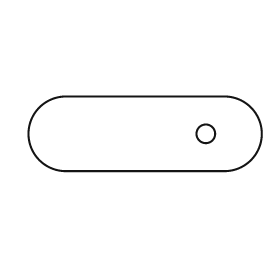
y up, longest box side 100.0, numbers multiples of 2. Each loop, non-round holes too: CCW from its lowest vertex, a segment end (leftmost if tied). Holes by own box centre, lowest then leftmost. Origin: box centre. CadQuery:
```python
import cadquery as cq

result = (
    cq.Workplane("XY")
    .moveTo(-34.0, -16.0)
    .lineTo(34.0, -16.0)
    .threePointArc((50.0, 0.0), (34.0, 16.0))
    .lineTo(-34.0, 16.0)
    .threePointArc((-50.0, 0.0), (-34.0, -16.0))
    .close()
    .moveTo(26.0, 0.0)
    .circle(4.0)
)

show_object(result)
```